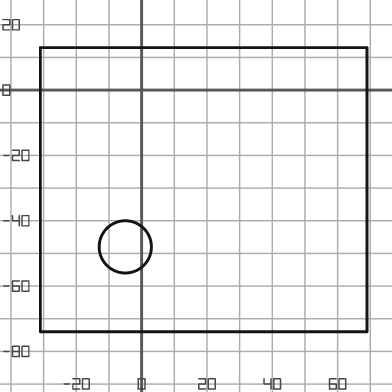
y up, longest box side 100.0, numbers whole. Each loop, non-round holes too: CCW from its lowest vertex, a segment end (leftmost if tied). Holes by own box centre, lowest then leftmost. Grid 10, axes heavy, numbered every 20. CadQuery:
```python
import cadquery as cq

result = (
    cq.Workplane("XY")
    .moveTo(-31.0, -74.0)
    .lineTo(69.0, -74.0)
    .lineTo(69.0, 13.0)
    .lineTo(-31.0, 13.0)
    .close()
    .moveTo(-5.0, -48.0)
    .circle(8.0)
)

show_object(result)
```